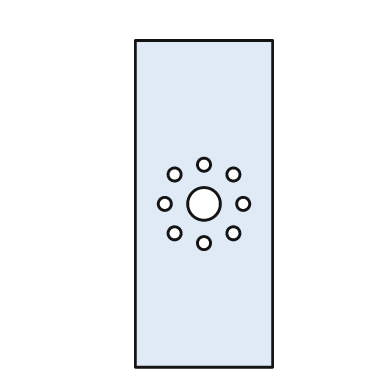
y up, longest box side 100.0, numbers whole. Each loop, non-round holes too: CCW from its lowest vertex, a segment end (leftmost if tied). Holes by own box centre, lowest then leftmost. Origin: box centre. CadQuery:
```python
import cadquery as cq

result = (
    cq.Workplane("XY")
    .moveTo(-21.0, -50.0)
    .lineTo(21.0, -50.0)
    .lineTo(21.0, 50.0)
    .lineTo(-21.0, 50.0)
    .close()
    .moveTo(0.0, -12.0)
    .circle(2.0)
    .moveTo(-9.0, -9.0)
    .circle(2.0)
    .moveTo(9.0, -9.0)
    .circle(2.0)
    .moveTo(-12.0, 0.0)
    .circle(2.0)
    .moveTo(0.0, 0.0)
    .circle(5.0)
    .moveTo(12.0, 0.0)
    .circle(2.0)
    .moveTo(-9.0, 9.0)
    .circle(2.0)
    .moveTo(9.0, 9.0)
    .circle(2.0)
    .moveTo(0.0, 12.0)
    .circle(2.0)
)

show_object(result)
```